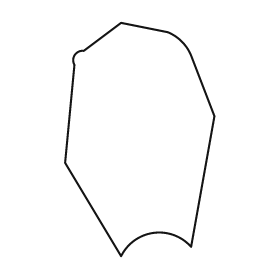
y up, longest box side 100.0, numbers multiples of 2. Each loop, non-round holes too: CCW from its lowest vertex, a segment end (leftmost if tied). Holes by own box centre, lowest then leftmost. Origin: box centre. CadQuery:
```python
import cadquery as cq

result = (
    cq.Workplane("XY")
    .moveTo(-8.0, -50.0)
    .threePointArc((6.0, -40.0), (22.0, -46.0))
    .lineTo(32.0, 10.0)
    .lineTo(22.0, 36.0)
    .threePointArc((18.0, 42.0), (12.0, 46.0))
    .lineTo(-8.0, 50.0)
    .lineTo(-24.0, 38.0)
    .threePointArc((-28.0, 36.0), (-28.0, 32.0))
    .lineTo(-32.0, -10.0)
    .close()
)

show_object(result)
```